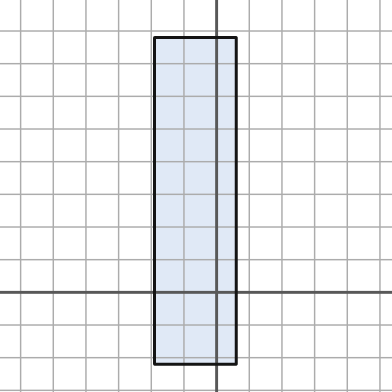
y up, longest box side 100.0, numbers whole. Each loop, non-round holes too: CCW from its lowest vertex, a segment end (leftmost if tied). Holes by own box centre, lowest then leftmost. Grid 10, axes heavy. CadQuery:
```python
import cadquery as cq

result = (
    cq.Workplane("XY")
    .moveTo(-19.0, -22.0)
    .lineTo(6.0, -22.0)
    .lineTo(6.0, 78.0)
    .lineTo(-19.0, 78.0)
    .close()
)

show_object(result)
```